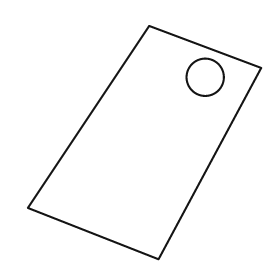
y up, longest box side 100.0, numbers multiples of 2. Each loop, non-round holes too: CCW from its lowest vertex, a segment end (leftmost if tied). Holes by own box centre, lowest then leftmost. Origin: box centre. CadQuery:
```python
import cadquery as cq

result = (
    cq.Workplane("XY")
    .moveTo(6.0, -50.0)
    .lineTo(50.0, 32.0)
    .lineTo(2.0, 50.0)
    .lineTo(-50.0, -28.0)
    .close()
    .moveTo(26.0, 28.0)
    .circle(8.0)
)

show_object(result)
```